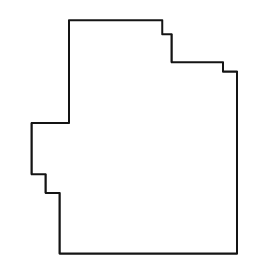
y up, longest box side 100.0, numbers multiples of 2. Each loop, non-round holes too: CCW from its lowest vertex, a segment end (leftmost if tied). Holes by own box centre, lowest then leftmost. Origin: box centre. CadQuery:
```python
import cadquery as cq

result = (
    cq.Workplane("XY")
    .moveTo(-32.0, -50.0)
    .lineTo(44.0, -50.0)
    .lineTo(44.0, 28.0)
    .lineTo(38.0, 28.0)
    .lineTo(38.0, 32.0)
    .lineTo(16.0, 32.0)
    .lineTo(16.0, 44.0)
    .lineTo(12.0, 44.0)
    .lineTo(12.0, 50.0)
    .lineTo(-28.0, 50.0)
    .lineTo(-28.0, 6.0)
    .lineTo(-44.0, 6.0)
    .lineTo(-44.0, -16.0)
    .lineTo(-38.0, -16.0)
    .lineTo(-38.0, -24.0)
    .lineTo(-32.0, -24.0)
    .close()
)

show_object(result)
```